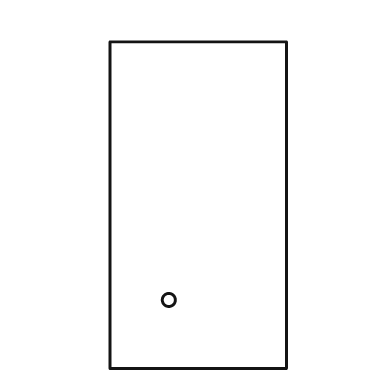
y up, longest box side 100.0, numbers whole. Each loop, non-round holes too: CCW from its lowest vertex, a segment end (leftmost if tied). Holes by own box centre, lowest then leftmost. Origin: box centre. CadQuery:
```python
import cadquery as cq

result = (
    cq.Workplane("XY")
    .moveTo(-27.0, -50.0)
    .lineTo(27.0, -50.0)
    .lineTo(27.0, 50.0)
    .lineTo(-27.0, 50.0)
    .close()
    .moveTo(-9.0, -29.0)
    .circle(2.0)
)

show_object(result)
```